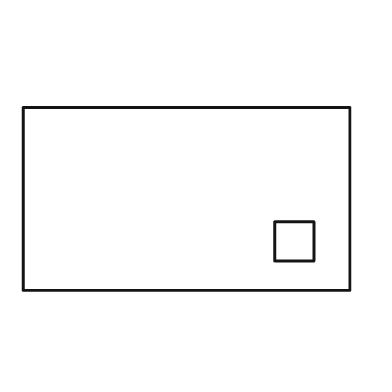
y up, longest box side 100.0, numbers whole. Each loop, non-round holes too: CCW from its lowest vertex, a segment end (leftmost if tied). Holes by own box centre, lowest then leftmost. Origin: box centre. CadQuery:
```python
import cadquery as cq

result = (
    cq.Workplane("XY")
    .moveTo(-50.0, -28.0)
    .lineTo(50.0, -28.0)
    .lineTo(50.0, 28.0)
    .lineTo(-50.0, 28.0)
    .close()
    .moveTo(27.0, -19.0)
    .lineTo(39.0, -19.0)
    .lineTo(39.0, -7.0)
    .lineTo(27.0, -7.0)
    .close()
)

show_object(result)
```